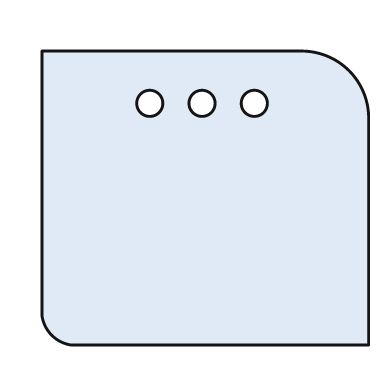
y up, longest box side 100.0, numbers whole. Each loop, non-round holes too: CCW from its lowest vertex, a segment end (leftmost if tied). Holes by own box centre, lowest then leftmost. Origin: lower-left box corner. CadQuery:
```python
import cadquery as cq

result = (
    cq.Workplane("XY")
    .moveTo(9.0, 0.0)
    .lineTo(100.0, 0.0)
    .lineTo(100.0, 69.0)
    .threePointArc((94.0, 84.0), (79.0, 90.0))
    .lineTo(0.0, 90.0)
    .lineTo(0.0, 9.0)
    .threePointArc((3.0, 3.0), (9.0, 0.0))
    .close()
    .moveTo(33.0, 74.0)
    .circle(4.0)
    .moveTo(49.0, 74.0)
    .circle(4.0)
    .moveTo(65.0, 74.0)
    .circle(4.0)
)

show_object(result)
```